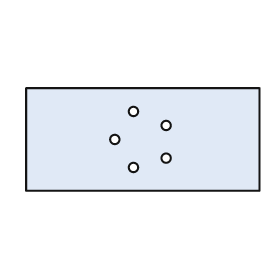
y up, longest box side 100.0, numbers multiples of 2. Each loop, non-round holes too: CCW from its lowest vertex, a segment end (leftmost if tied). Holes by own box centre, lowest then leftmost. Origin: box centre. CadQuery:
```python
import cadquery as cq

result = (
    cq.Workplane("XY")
    .moveTo(-50.0, -22.0)
    .lineTo(50.0, -22.0)
    .lineTo(50.0, 22.0)
    .lineTo(-50.0, 22.0)
    .close()
    .moveTo(-4.0, -12.0)
    .circle(2.0)
    .moveTo(10.0, -8.0)
    .circle(2.0)
    .moveTo(-12.0, 0.0)
    .circle(2.0)
    .moveTo(10.0, 6.0)
    .circle(2.0)
    .moveTo(-4.0, 12.0)
    .circle(2.0)
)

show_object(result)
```